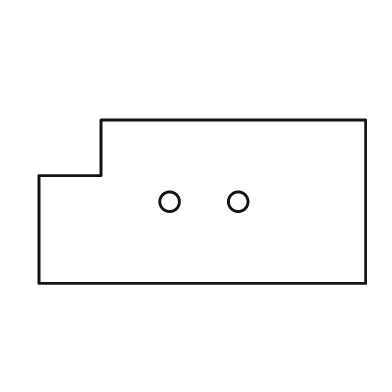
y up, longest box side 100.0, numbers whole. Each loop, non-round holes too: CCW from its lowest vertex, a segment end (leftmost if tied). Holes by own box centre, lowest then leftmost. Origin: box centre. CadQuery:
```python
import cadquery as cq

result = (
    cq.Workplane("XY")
    .moveTo(-50.0, -25.0)
    .lineTo(50.0, -25.0)
    .lineTo(50.0, 25.0)
    .lineTo(-31.0, 25.0)
    .lineTo(-31.0, 8.0)
    .lineTo(-50.0, 8.0)
    .close()
    .moveTo(-10.0, 0.0)
    .circle(3.0)
    .moveTo(11.0, 0.0)
    .circle(3.0)
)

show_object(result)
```